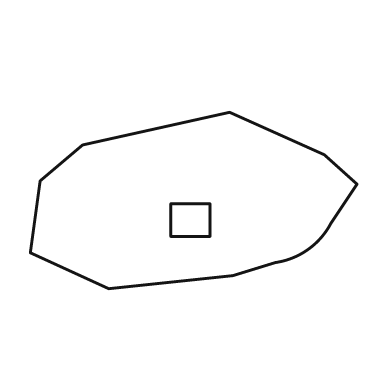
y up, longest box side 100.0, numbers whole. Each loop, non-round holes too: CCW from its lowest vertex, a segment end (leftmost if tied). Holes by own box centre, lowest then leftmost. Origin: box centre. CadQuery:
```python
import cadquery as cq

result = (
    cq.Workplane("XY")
    .moveTo(-26.0, -27.0)
    .lineTo(12.0, -23.0)
    .lineTo(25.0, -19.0)
    .threePointArc((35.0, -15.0), (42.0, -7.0))
    .lineTo(50.0, 5.0)
    .lineTo(40.0, 14.0)
    .lineTo(11.0, 27.0)
    .lineTo(-34.0, 17.0)
    .lineTo(-47.0, 6.0)
    .lineTo(-50.0, -16.0)
    .close()
    .moveTo(-7.0, -11.0)
    .lineTo(5.0, -11.0)
    .lineTo(5.0, -1.0)
    .lineTo(-7.0, -1.0)
    .close()
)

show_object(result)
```